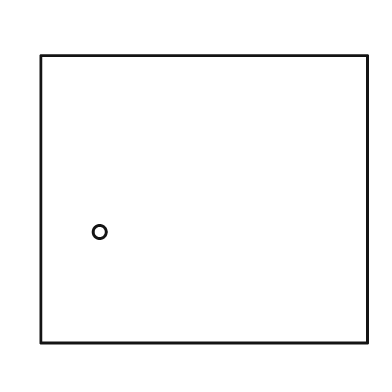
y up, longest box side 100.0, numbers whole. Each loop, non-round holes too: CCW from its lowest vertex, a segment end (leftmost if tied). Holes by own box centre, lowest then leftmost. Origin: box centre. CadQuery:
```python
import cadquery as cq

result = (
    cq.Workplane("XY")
    .moveTo(-50.0, -44.0)
    .lineTo(50.0, -44.0)
    .lineTo(50.0, 44.0)
    .lineTo(-50.0, 44.0)
    .close()
    .moveTo(-32.0, -10.0)
    .circle(2.0)
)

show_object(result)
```